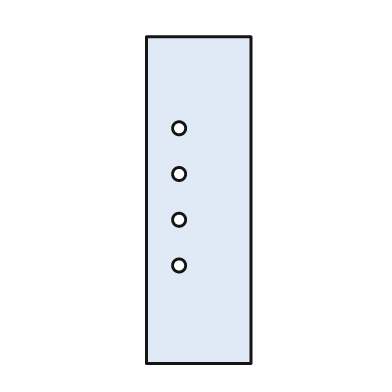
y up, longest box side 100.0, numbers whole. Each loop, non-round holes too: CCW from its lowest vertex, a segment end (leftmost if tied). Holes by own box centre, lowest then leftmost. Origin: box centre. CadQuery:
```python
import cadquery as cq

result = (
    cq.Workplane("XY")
    .moveTo(-16.0, -50.0)
    .lineTo(16.0, -50.0)
    .lineTo(16.0, 50.0)
    .lineTo(-16.0, 50.0)
    .close()
    .moveTo(-6.0, -20.0)
    .circle(2.0)
    .moveTo(-6.0, -6.0)
    .circle(2.0)
    .moveTo(-6.0, 8.0)
    .circle(2.0)
    .moveTo(-6.0, 22.0)
    .circle(2.0)
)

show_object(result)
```